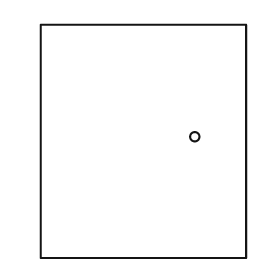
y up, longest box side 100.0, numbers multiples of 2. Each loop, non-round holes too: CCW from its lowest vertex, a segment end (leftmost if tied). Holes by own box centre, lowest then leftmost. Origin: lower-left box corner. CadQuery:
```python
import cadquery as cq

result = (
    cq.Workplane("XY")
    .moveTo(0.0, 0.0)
    .lineTo(88.0, 0.0)
    .lineTo(88.0, 100.0)
    .lineTo(0.0, 100.0)
    .close()
    .moveTo(66.0, 52.0)
    .circle(2.0)
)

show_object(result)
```